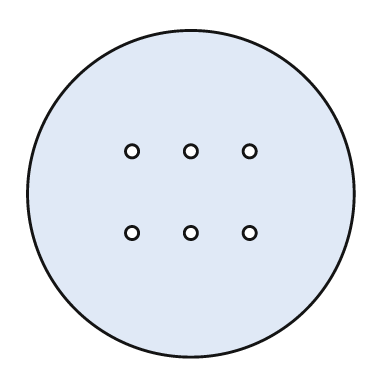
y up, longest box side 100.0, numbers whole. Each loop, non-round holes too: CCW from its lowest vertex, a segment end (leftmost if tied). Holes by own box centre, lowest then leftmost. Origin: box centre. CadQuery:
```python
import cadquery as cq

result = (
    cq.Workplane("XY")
    .moveTo(0.0, 0.0)
    .circle(50.0)
    .moveTo(-18.0, -12.0)
    .circle(2.0)
    .moveTo(0.0, -12.0)
    .circle(2.0)
    .moveTo(18.0, -12.0)
    .circle(2.0)
    .moveTo(-18.0, 13.0)
    .circle(2.0)
    .moveTo(0.0, 13.0)
    .circle(2.0)
    .moveTo(18.0, 13.0)
    .circle(2.0)
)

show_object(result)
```